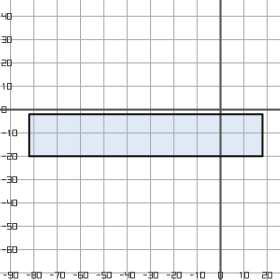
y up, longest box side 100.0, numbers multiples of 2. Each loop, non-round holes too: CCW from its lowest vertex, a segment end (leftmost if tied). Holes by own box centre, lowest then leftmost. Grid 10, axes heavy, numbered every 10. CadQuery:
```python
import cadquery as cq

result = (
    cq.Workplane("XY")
    .moveTo(-82.0, -20.0)
    .lineTo(18.0, -20.0)
    .lineTo(18.0, -2.0)
    .lineTo(-82.0, -2.0)
    .close()
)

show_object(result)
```